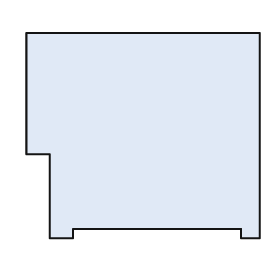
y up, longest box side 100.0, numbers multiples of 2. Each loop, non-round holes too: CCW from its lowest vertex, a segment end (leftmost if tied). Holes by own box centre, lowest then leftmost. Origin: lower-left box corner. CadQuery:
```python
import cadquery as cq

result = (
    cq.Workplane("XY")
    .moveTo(10.0, 0.0)
    .lineTo(20.0, 0.0)
    .lineTo(20.0, 4.0)
    .lineTo(92.0, 4.0)
    .lineTo(92.0, 0.0)
    .lineTo(100.0, 0.0)
    .lineTo(100.0, 88.0)
    .lineTo(0.0, 88.0)
    .lineTo(0.0, 36.0)
    .lineTo(10.0, 36.0)
    .close()
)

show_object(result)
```